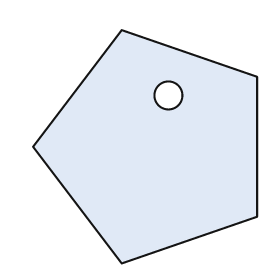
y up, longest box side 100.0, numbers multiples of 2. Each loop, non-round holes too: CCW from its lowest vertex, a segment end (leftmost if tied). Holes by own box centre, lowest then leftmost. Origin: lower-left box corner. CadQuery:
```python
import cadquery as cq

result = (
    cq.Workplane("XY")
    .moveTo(38.0, 0.0)
    .lineTo(96.0, 20.0)
    .lineTo(96.0, 80.0)
    .lineTo(38.0, 100.0)
    .lineTo(0.0, 50.0)
    .close()
    .moveTo(58.0, 72.0)
    .circle(6.0)
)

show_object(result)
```